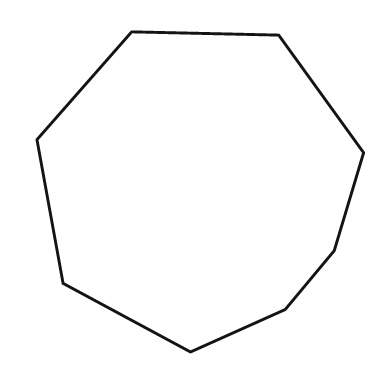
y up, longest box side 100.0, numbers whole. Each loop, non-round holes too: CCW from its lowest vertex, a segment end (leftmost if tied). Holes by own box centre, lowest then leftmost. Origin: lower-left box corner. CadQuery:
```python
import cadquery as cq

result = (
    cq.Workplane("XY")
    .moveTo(47.0, 0.0)
    .lineTo(76.0, 13.0)
    .lineTo(91.0, 31.0)
    .lineTo(100.0, 61.0)
    .lineTo(74.0, 97.0)
    .lineTo(29.0, 98.0)
    .lineTo(0.0, 65.0)
    .lineTo(8.0, 21.0)
    .close()
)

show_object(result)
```